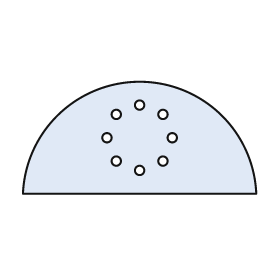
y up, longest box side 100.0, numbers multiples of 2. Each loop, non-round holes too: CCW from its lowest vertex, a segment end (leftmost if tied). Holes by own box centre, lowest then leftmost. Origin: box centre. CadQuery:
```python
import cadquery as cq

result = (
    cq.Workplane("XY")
    .moveTo(-50.0, -24.0)
    .lineTo(50.0, -24.0)
    .threePointArc((0.0, 24.0), (-50.0, -24.0))
    .close()
    .moveTo(0.0, -14.0)
    .circle(2.0)
    .moveTo(-10.0, -10.0)
    .circle(2.0)
    .moveTo(10.0, -10.0)
    .circle(2.0)
    .moveTo(-14.0, 0.0)
    .circle(2.0)
    .moveTo(14.0, 0.0)
    .circle(2.0)
    .moveTo(-10.0, 10.0)
    .circle(2.0)
    .moveTo(10.0, 10.0)
    .circle(2.0)
    .moveTo(0.0, 14.0)
    .circle(2.0)
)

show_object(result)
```